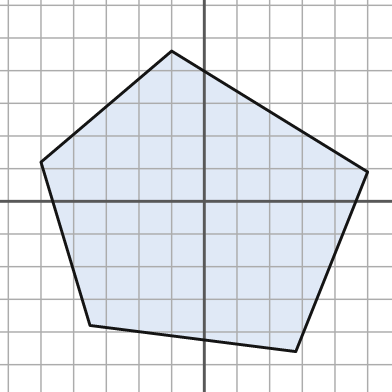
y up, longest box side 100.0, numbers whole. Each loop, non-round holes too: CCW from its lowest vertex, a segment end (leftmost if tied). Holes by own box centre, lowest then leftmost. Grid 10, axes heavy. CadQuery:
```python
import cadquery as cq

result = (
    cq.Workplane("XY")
    .moveTo(28.0, -46.0)
    .lineTo(50.0, 9.0)
    .lineTo(-10.0, 46.0)
    .lineTo(-50.0, 12.0)
    .lineTo(-35.0, -38.0)
    .close()
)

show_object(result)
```